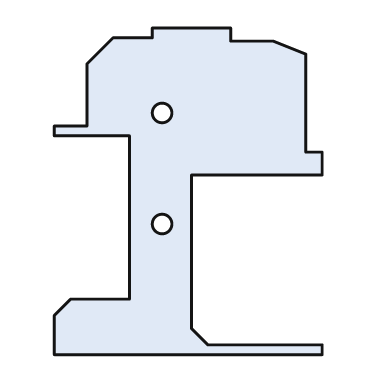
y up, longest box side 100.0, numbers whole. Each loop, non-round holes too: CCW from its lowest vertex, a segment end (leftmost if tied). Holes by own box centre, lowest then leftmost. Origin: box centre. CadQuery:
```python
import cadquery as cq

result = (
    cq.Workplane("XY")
    .moveTo(-41.0, -50.0)
    .lineTo(41.0, -50.0)
    .lineTo(41.0, -47.0)
    .lineTo(6.0, -47.0)
    .lineTo(1.0, -42.0)
    .lineTo(1.0, 5.0)
    .lineTo(41.0, 5.0)
    .lineTo(41.0, 12.0)
    .lineTo(36.0, 12.0)
    .lineTo(36.0, 42.0)
    .lineTo(26.0, 46.0)
    .lineTo(13.0, 46.0)
    .lineTo(13.0, 50.0)
    .lineTo(-11.0, 50.0)
    .lineTo(-11.0, 47.0)
    .lineTo(-23.0, 47.0)
    .lineTo(-31.0, 39.0)
    .lineTo(-31.0, 20.0)
    .lineTo(-41.0, 20.0)
    .lineTo(-41.0, 17.0)
    .lineTo(-18.0, 17.0)
    .lineTo(-18.0, -33.0)
    .lineTo(-36.0, -33.0)
    .lineTo(-41.0, -38.0)
    .close()
    .moveTo(-8.0, -10.0)
    .circle(3.0)
    .moveTo(-8.0, 24.0)
    .circle(3.0)
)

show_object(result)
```